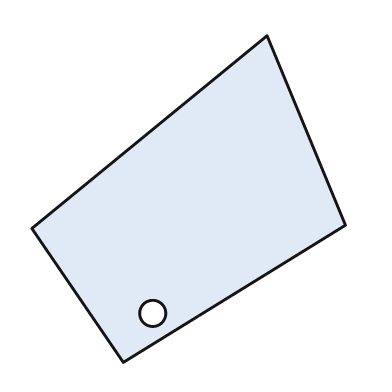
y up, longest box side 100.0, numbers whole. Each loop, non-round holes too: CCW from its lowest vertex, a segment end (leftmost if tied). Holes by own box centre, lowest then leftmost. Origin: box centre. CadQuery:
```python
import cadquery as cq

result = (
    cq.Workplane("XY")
    .moveTo(-20.0, -50.0)
    .lineTo(48.0, -8.0)
    .lineTo(24.0, 50.0)
    .lineTo(-48.0, -9.0)
    .close()
    .moveTo(-11.0, -35.0)
    .circle(4.0)
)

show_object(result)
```